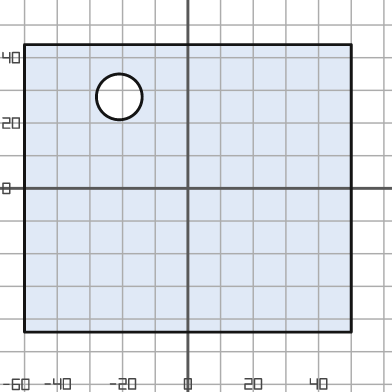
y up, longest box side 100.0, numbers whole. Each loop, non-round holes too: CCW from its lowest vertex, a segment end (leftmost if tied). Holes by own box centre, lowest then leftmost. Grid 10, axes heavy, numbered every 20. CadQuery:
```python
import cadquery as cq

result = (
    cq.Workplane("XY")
    .moveTo(-50.0, -44.0)
    .lineTo(50.0, -44.0)
    .lineTo(50.0, 44.0)
    .lineTo(-50.0, 44.0)
    .close()
    .moveTo(-21.0, 28.0)
    .circle(7.0)
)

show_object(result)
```